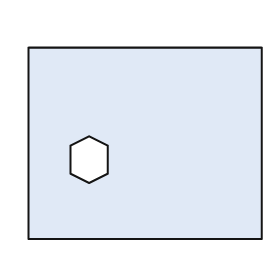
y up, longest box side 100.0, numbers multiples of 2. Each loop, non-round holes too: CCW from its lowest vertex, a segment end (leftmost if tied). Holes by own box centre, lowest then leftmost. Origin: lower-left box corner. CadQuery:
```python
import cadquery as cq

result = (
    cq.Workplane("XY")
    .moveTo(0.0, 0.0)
    .lineTo(100.0, 0.0)
    .lineTo(100.0, 82.0)
    .lineTo(0.0, 82.0)
    .close()
    .moveTo(26.0, 24.0)
    .lineTo(34.0, 28.0)
    .lineTo(34.0, 40.0)
    .lineTo(26.0, 44.0)
    .lineTo(18.0, 40.0)
    .lineTo(18.0, 28.0)
    .close()
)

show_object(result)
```